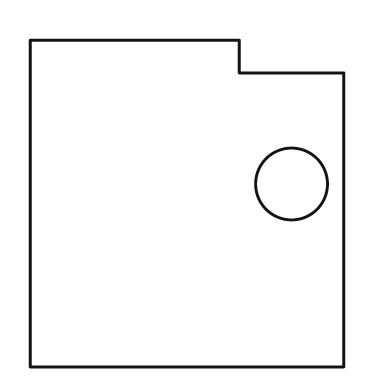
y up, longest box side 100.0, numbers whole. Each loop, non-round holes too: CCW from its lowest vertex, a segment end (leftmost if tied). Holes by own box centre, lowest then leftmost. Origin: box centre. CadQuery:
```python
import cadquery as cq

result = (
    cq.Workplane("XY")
    .moveTo(-48.0, -50.0)
    .lineTo(48.0, -50.0)
    .lineTo(48.0, 40.0)
    .lineTo(16.0, 40.0)
    .lineTo(16.0, 50.0)
    .lineTo(-48.0, 50.0)
    .close()
    .moveTo(32.0, 6.0)
    .circle(11.0)
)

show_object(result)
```